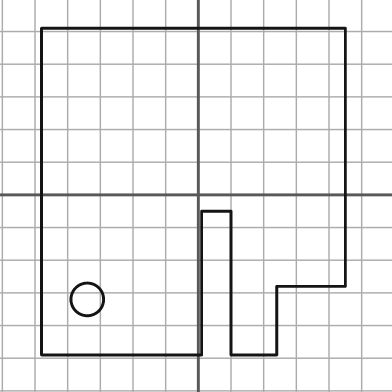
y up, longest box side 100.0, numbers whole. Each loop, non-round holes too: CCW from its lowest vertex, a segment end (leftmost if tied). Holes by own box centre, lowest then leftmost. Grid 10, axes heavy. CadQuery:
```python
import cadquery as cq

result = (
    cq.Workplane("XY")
    .moveTo(-48.0, -49.0)
    .lineTo(1.0, -49.0)
    .lineTo(1.0, -5.0)
    .lineTo(10.0, -5.0)
    .lineTo(10.0, -49.0)
    .lineTo(24.0, -49.0)
    .lineTo(24.0, -28.0)
    .lineTo(45.0, -28.0)
    .lineTo(45.0, 51.0)
    .lineTo(-48.0, 51.0)
    .close()
    .moveTo(-34.0, -32.0)
    .circle(5.0)
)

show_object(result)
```